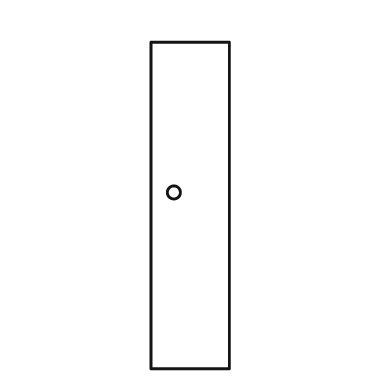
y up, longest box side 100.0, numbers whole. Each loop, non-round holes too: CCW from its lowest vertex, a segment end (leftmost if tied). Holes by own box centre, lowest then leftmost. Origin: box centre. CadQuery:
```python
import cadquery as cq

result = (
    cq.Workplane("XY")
    .moveTo(-12.0, -50.0)
    .lineTo(12.0, -50.0)
    .lineTo(12.0, 50.0)
    .lineTo(-12.0, 50.0)
    .close()
    .moveTo(-5.0, 4.0)
    .circle(2.0)
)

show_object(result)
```